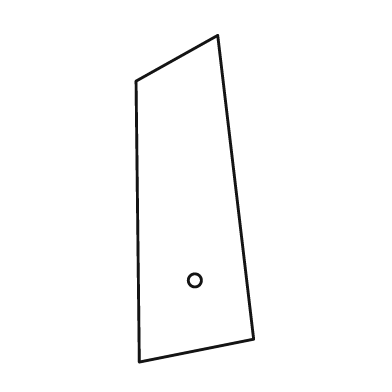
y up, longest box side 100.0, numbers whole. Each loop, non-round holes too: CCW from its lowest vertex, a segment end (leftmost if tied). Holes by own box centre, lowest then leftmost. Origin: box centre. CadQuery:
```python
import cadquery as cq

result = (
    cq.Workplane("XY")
    .moveTo(-17.0, -50.0)
    .lineTo(18.0, -43.0)
    .lineTo(7.0, 50.0)
    .lineTo(-18.0, 36.0)
    .close()
    .moveTo(0.0, -25.0)
    .circle(2.0)
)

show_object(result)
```